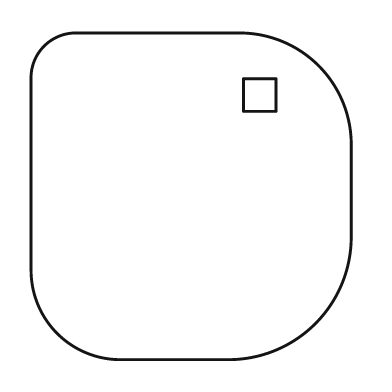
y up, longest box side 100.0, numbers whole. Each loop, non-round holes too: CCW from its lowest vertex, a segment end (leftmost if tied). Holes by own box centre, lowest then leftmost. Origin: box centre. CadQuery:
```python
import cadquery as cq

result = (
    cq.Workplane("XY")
    .moveTo(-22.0, -50.0)
    .lineTo(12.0, -50.0)
    .threePointArc((38.0, -39.0), (49.0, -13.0))
    .lineTo(49.0, 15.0)
    .threePointArc((39.0, 40.0), (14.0, 50.0))
    .lineTo(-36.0, 50.0)
    .threePointArc((-45.0, 46.0), (-49.0, 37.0))
    .lineTo(-49.0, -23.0)
    .threePointArc((-41.0, -42.0), (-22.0, -50.0))
    .close()
    .moveTo(16.0, 26.0)
    .lineTo(26.0, 26.0)
    .lineTo(26.0, 36.0)
    .lineTo(16.0, 36.0)
    .close()
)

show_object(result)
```